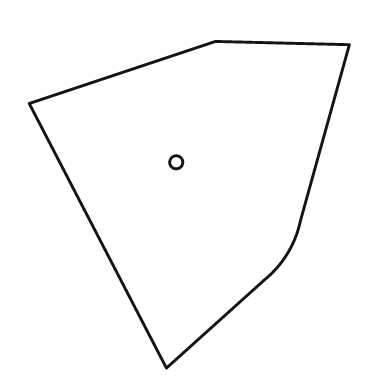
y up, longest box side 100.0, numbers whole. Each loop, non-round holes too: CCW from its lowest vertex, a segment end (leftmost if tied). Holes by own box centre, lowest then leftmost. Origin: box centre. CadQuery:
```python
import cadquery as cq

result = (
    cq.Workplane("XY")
    .moveTo(-7.0, -50.0)
    .lineTo(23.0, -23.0)
    .threePointArc((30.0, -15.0), (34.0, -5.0))
    .lineTo(49.0, 49.0)
    .lineTo(8.0, 50.0)
    .lineTo(-49.0, 31.0)
    .close()
    .moveTo(-4.0, 13.0)
    .circle(2.0)
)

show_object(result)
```